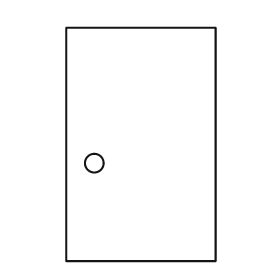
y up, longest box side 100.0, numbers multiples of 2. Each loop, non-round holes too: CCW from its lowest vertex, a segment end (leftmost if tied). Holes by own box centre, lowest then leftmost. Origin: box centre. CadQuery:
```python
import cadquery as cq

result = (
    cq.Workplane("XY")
    .moveTo(-32.0, -50.0)
    .lineTo(32.0, -50.0)
    .lineTo(32.0, 50.0)
    .lineTo(-32.0, 50.0)
    .close()
    .moveTo(-20.0, -8.0)
    .circle(4.0)
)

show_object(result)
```